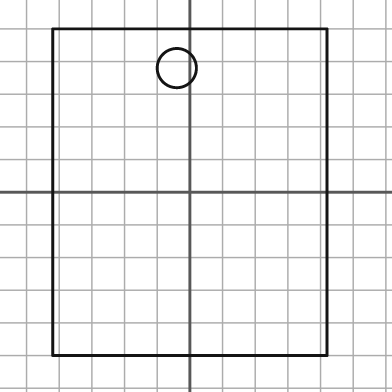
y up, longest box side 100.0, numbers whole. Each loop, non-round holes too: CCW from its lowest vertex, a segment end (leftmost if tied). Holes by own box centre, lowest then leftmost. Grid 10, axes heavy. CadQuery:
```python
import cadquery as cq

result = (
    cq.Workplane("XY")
    .moveTo(-42.0, -50.0)
    .lineTo(42.0, -50.0)
    .lineTo(42.0, 50.0)
    .lineTo(-42.0, 50.0)
    .close()
    .moveTo(-4.0, 38.0)
    .circle(6.0)
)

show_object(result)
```